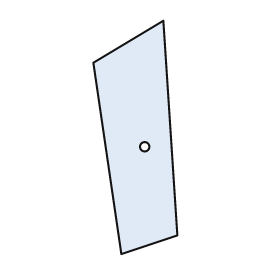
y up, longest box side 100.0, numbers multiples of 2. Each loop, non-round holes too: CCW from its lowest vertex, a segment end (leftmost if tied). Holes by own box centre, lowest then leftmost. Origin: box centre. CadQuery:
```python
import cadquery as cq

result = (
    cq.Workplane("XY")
    .moveTo(-6.0, -50.0)
    .lineTo(18.0, -42.0)
    .lineTo(12.0, 50.0)
    .lineTo(-18.0, 32.0)
    .close()
    .moveTo(4.0, -4.0)
    .circle(2.0)
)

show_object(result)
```